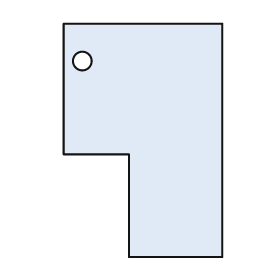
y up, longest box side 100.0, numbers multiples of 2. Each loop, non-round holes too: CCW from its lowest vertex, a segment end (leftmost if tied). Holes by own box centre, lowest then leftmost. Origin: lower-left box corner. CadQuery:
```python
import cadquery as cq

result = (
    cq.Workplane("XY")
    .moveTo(28.0, 0.0)
    .lineTo(68.0, 0.0)
    .lineTo(68.0, 100.0)
    .lineTo(0.0, 100.0)
    .lineTo(0.0, 44.0)
    .lineTo(28.0, 44.0)
    .close()
    .moveTo(8.0, 84.0)
    .circle(4.0)
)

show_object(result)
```